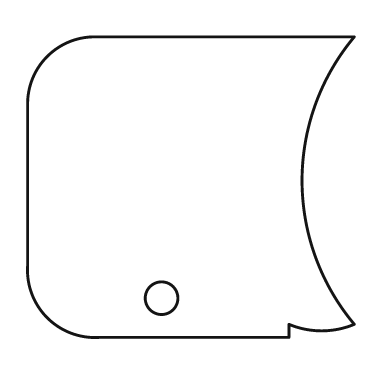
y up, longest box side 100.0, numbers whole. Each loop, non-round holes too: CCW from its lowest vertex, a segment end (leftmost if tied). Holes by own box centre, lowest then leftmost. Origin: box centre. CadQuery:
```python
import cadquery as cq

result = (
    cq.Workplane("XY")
    .moveTo(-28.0, -46.0)
    .lineTo(30.0, -46.0)
    .lineTo(30.0, -42.0)
    .threePointArc((40.0, -44.0), (50.0, -42.0))
    .threePointArc((34.0, 2.0), (50.0, 46.0))
    .lineTo(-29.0, 46.0)
    .threePointArc((-44.0, 40.0), (-50.0, 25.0))
    .lineTo(-50.0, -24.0)
    .threePointArc((-44.0, -40.0), (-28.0, -46.0))
    .close()
    .moveTo(-9.0, -34.0)
    .circle(5.0)
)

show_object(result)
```